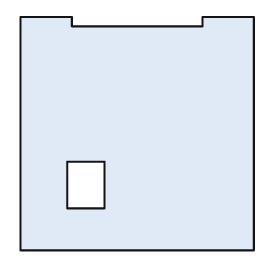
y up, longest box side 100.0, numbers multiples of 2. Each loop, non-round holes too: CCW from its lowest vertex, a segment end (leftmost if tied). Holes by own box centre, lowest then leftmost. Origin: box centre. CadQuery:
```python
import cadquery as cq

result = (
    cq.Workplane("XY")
    .moveTo(-50.0, -50.0)
    .lineTo(50.0, -50.0)
    .lineTo(50.0, 50.0)
    .lineTo(28.0, 50.0)
    .lineTo(28.0, 46.0)
    .lineTo(-28.0, 46.0)
    .lineTo(-28.0, 50.0)
    .lineTo(-50.0, 50.0)
    .close()
    .moveTo(-30.0, -32.0)
    .lineTo(-14.0, -32.0)
    .lineTo(-14.0, -12.0)
    .lineTo(-30.0, -12.0)
    .close()
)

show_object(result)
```